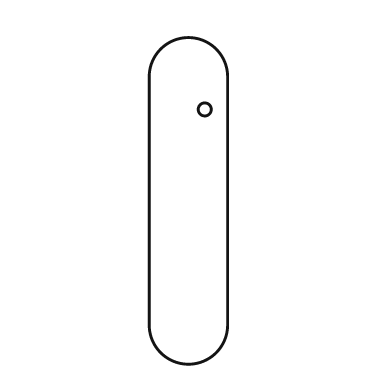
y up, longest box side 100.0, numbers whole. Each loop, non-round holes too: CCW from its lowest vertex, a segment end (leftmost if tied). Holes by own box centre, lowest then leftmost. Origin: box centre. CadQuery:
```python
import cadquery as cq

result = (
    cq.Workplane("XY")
    .moveTo(-12.0, -38.0)
    .threePointArc((0.0, -50.0), (12.0, -38.0))
    .lineTo(12.0, 38.0)
    .threePointArc((0.0, 50.0), (-12.0, 38.0))
    .close()
    .moveTo(5.0, 28.0)
    .circle(2.0)
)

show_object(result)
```